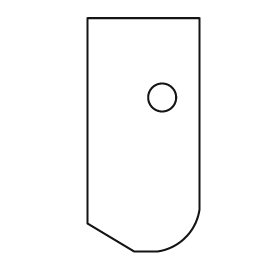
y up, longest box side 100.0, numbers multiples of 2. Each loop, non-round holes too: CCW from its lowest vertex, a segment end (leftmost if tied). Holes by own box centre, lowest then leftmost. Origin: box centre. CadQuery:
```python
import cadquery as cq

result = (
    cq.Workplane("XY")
    .moveTo(-4.0, -50.0)
    .lineTo(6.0, -50.0)
    .threePointArc((18.0, -44.0), (24.0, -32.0))
    .lineTo(24.0, 50.0)
    .lineTo(-24.0, 50.0)
    .lineTo(-24.0, -38.0)
    .close()
    .moveTo(8.0, 16.0)
    .circle(6.0)
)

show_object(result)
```